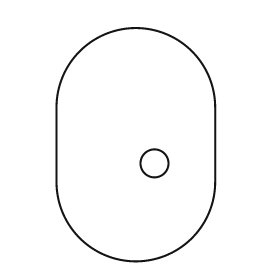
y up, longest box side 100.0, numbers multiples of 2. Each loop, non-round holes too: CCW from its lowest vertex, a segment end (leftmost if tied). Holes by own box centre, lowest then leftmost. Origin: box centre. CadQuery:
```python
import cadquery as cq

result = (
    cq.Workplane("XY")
    .moveTo(-34.0, -16.0)
    .threePointArc((0.0, -50.0), (34.0, -16.0))
    .lineTo(34.0, 16.0)
    .threePointArc((0.0, 50.0), (-34.0, 16.0))
    .close()
    .moveTo(8.0, -8.0)
    .circle(6.0)
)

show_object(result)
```